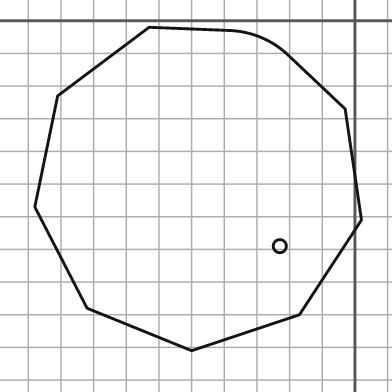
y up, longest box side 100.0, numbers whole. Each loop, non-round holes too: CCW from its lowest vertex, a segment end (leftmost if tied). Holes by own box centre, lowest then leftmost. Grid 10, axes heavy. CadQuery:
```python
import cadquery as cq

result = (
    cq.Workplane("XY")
    .moveTo(-50.0, -101.0)
    .lineTo(-17.0, -90.0)
    .lineTo(2.0, -61.0)
    .lineTo(-3.0, -27.0)
    .lineTo(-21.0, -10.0)
    .threePointArc((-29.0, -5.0), (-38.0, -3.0))
    .lineTo(-63.0, -2.0)
    .lineTo(-91.0, -23.0)
    .lineTo(-98.0, -57.0)
    .lineTo(-82.0, -88.0)
    .close()
    .moveTo(-23.0, -69.0)
    .circle(2.0)
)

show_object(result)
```